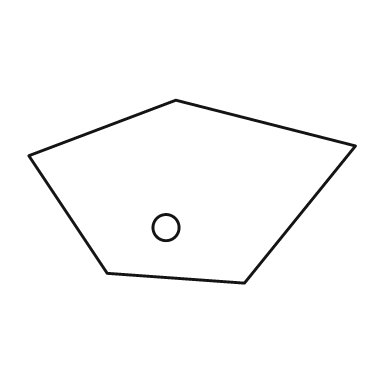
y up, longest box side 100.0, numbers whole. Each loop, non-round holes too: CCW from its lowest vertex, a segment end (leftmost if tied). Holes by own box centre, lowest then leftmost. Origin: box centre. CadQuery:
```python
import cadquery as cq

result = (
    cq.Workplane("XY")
    .moveTo(16.0, -28.0)
    .lineTo(50.0, 14.0)
    .lineTo(-5.0, 28.0)
    .lineTo(-50.0, 11.0)
    .lineTo(-26.0, -25.0)
    .close()
    .moveTo(-8.0, -11.0)
    .circle(4.0)
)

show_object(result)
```